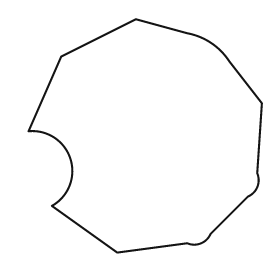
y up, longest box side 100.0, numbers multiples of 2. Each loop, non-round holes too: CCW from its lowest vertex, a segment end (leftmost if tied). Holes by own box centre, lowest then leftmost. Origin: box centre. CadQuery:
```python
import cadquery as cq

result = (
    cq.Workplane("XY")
    .moveTo(-12.0, -50.0)
    .lineTo(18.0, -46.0)
    .threePointArc((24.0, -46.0), (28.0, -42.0))
    .lineTo(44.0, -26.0)
    .threePointArc((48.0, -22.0), (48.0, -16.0))
    .lineTo(50.0, 14.0)
    .lineTo(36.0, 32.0)
    .threePointArc((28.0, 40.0), (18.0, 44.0))
    .lineTo(-4.0, 50.0)
    .lineTo(-36.0, 34.0)
    .lineTo(-50.0, 2.0)
    .threePointArc((-32.0, -10.0), (-40.0, -30.0))
    .close()
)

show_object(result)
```